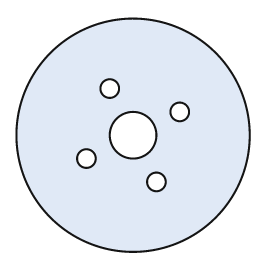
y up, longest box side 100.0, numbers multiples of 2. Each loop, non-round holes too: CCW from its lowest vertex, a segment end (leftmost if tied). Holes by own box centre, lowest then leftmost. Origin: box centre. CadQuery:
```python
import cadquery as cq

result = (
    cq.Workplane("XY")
    .moveTo(0.0, 0.0)
    .circle(50.0)
    .moveTo(10.0, -20.0)
    .circle(4.0)
    .moveTo(-20.0, -10.0)
    .circle(4.0)
    .moveTo(0.0, 0.0)
    .circle(10.0)
    .moveTo(20.0, 10.0)
    .circle(4.0)
    .moveTo(-10.0, 20.0)
    .circle(4.0)
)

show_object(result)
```